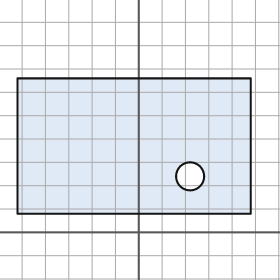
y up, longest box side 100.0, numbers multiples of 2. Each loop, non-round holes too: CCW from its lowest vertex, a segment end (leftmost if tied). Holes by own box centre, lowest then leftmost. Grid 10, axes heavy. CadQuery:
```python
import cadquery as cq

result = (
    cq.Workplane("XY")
    .moveTo(-52.0, 8.0)
    .lineTo(48.0, 8.0)
    .lineTo(48.0, 66.0)
    .lineTo(-52.0, 66.0)
    .close()
    .moveTo(22.0, 24.0)
    .circle(6.0)
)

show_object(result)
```